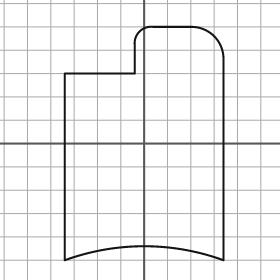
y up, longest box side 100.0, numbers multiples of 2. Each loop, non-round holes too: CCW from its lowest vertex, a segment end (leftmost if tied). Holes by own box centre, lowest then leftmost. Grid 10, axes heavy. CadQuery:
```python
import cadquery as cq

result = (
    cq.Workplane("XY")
    .moveTo(-34.0, -50.0)
    .threePointArc((0.0, -44.0), (34.0, -50.0))
    .lineTo(34.0, 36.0)
    .threePointArc((30.0, 46.0), (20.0, 50.0))
    .lineTo(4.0, 50.0)
    .threePointArc((-2.0, 48.0), (-4.0, 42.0))
    .lineTo(-4.0, 30.0)
    .lineTo(-34.0, 30.0)
    .close()
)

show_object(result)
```